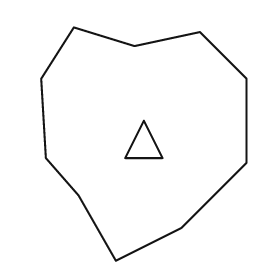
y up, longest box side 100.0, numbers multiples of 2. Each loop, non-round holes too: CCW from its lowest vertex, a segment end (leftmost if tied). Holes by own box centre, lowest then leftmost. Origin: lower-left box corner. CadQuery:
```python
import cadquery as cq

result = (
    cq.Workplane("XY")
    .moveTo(32.0, 0.0)
    .lineTo(60.0, 14.0)
    .lineTo(88.0, 42.0)
    .lineTo(88.0, 78.0)
    .lineTo(68.0, 98.0)
    .lineTo(40.0, 92.0)
    .lineTo(14.0, 100.0)
    .lineTo(0.0, 78.0)
    .lineTo(2.0, 44.0)
    .lineTo(16.0, 28.0)
    .close()
    .moveTo(36.0, 44.0)
    .lineTo(52.0, 44.0)
    .lineTo(44.0, 60.0)
    .close()
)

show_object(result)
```